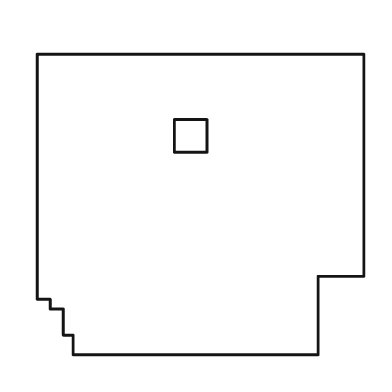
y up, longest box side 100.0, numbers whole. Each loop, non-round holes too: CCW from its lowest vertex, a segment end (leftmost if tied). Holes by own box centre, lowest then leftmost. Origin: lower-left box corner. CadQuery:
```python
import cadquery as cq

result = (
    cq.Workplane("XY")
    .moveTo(11.0, 0.0)
    .lineTo(86.0, 0.0)
    .lineTo(86.0, 24.0)
    .lineTo(100.0, 24.0)
    .lineTo(100.0, 92.0)
    .lineTo(0.0, 92.0)
    .lineTo(0.0, 17.0)
    .lineTo(4.0, 17.0)
    .lineTo(4.0, 14.0)
    .lineTo(8.0, 14.0)
    .lineTo(8.0, 6.0)
    .lineTo(11.0, 6.0)
    .close()
    .moveTo(42.0, 62.0)
    .lineTo(52.0, 62.0)
    .lineTo(52.0, 72.0)
    .lineTo(42.0, 72.0)
    .close()
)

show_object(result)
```